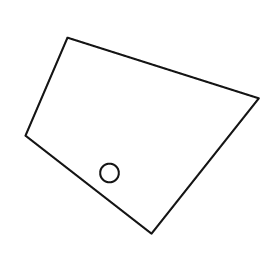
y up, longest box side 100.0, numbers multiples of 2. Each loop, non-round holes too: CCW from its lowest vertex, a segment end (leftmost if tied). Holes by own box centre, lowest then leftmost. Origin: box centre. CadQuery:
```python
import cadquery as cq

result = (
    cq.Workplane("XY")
    .moveTo(4.0, -42.0)
    .lineTo(50.0, 16.0)
    .lineTo(-32.0, 42.0)
    .lineTo(-50.0, 0.0)
    .close()
    .moveTo(-14.0, -16.0)
    .circle(4.0)
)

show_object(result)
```